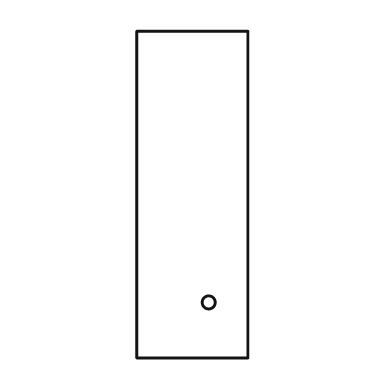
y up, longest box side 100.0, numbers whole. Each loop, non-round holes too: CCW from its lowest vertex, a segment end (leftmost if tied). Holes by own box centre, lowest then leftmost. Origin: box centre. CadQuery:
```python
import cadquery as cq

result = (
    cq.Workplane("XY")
    .moveTo(-17.0, -50.0)
    .lineTo(17.0, -50.0)
    .lineTo(17.0, 50.0)
    .lineTo(-17.0, 50.0)
    .close()
    .moveTo(5.0, -33.0)
    .circle(2.0)
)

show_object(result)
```